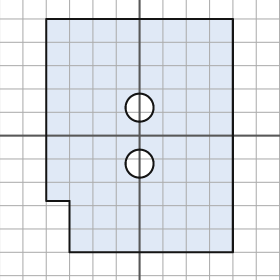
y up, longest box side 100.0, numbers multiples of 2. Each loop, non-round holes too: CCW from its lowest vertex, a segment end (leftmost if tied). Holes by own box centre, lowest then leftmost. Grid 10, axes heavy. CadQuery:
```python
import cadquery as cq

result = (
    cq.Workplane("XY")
    .moveTo(-30.0, -50.0)
    .lineTo(40.0, -50.0)
    .lineTo(40.0, 50.0)
    .lineTo(-40.0, 50.0)
    .lineTo(-40.0, -28.0)
    .lineTo(-30.0, -28.0)
    .close()
    .moveTo(0.0, -12.0)
    .circle(6.0)
    .moveTo(0.0, 12.0)
    .circle(6.0)
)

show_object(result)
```